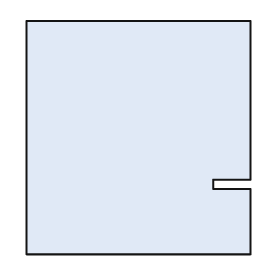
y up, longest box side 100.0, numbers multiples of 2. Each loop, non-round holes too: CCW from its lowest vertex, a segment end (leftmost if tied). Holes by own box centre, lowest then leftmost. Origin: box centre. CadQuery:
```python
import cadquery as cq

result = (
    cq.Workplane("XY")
    .moveTo(-48.0, -50.0)
    .lineTo(48.0, -50.0)
    .lineTo(48.0, -22.0)
    .lineTo(32.0, -22.0)
    .lineTo(32.0, -18.0)
    .lineTo(48.0, -18.0)
    .lineTo(48.0, 50.0)
    .lineTo(-48.0, 50.0)
    .close()
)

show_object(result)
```